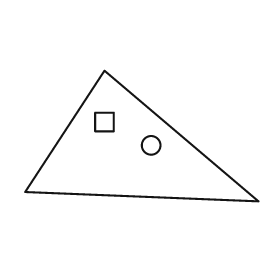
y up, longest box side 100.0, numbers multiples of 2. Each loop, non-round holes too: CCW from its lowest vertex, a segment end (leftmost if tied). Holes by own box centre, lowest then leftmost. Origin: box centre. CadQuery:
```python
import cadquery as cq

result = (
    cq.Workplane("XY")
    .moveTo(50.0, -28.0)
    .lineTo(-16.0, 28.0)
    .lineTo(-50.0, -24.0)
    .close()
    .moveTo(4.0, -4.0)
    .circle(4.0)
    .moveTo(-20.0, 2.0)
    .lineTo(-12.0, 2.0)
    .lineTo(-12.0, 10.0)
    .lineTo(-20.0, 10.0)
    .close()
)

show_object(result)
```